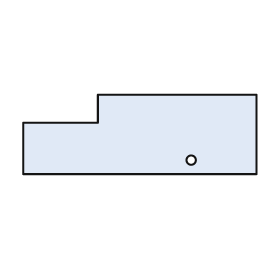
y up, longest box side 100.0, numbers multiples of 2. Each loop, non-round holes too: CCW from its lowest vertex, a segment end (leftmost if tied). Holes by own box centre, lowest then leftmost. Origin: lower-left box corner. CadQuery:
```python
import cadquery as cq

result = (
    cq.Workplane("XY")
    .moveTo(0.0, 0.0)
    .lineTo(100.0, 0.0)
    .lineTo(100.0, 34.0)
    .lineTo(32.0, 34.0)
    .lineTo(32.0, 22.0)
    .lineTo(0.0, 22.0)
    .close()
    .moveTo(72.0, 6.0)
    .circle(2.0)
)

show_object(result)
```